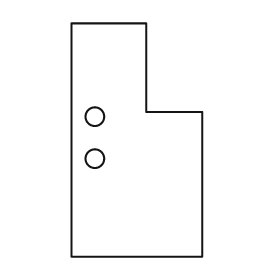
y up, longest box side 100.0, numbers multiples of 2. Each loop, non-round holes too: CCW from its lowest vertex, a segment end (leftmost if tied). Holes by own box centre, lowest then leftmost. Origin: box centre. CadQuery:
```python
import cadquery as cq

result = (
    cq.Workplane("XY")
    .moveTo(-28.0, -50.0)
    .lineTo(28.0, -50.0)
    .lineTo(28.0, 12.0)
    .lineTo(4.0, 12.0)
    .lineTo(4.0, 50.0)
    .lineTo(-28.0, 50.0)
    .close()
    .moveTo(-18.0, -8.0)
    .circle(4.0)
    .moveTo(-18.0, 10.0)
    .circle(4.0)
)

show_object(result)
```